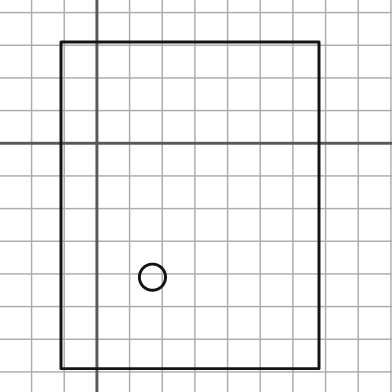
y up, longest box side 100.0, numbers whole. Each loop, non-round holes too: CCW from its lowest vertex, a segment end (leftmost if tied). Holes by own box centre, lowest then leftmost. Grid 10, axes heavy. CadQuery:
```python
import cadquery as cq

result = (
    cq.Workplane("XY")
    .moveTo(-11.0, -69.0)
    .lineTo(68.0, -69.0)
    .lineTo(68.0, 31.0)
    .lineTo(-11.0, 31.0)
    .close()
    .moveTo(17.0, -41.0)
    .circle(4.0)
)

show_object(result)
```